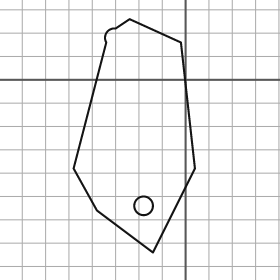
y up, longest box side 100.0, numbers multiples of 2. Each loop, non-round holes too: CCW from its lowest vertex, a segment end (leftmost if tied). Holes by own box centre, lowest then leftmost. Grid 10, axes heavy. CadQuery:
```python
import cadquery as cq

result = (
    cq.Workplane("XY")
    .moveTo(-14.0, -74.0)
    .lineTo(4.0, -38.0)
    .lineTo(-2.0, 16.0)
    .lineTo(-24.0, 26.0)
    .lineTo(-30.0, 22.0)
    .threePointArc((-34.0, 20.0), (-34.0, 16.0))
    .lineTo(-48.0, -38.0)
    .lineTo(-38.0, -56.0)
    .close()
    .moveTo(-18.0, -54.0)
    .circle(4.0)
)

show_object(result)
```